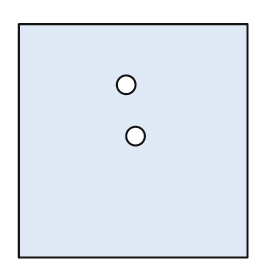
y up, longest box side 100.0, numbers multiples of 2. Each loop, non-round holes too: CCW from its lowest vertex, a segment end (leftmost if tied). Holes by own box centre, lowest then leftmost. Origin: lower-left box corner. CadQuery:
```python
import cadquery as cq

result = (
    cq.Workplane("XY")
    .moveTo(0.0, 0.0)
    .lineTo(98.0, 0.0)
    .lineTo(98.0, 100.0)
    .lineTo(0.0, 100.0)
    .close()
    .moveTo(50.0, 52.0)
    .circle(4.0)
    .moveTo(46.0, 74.0)
    .circle(4.0)
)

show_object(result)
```